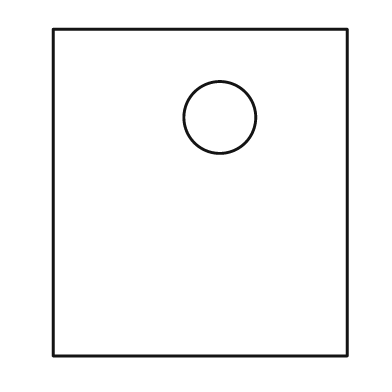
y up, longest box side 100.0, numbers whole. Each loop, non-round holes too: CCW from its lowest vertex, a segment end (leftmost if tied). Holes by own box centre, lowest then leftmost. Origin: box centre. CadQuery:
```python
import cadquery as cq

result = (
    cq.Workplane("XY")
    .moveTo(-45.0, -50.0)
    .lineTo(45.0, -50.0)
    .lineTo(45.0, 50.0)
    .lineTo(-45.0, 50.0)
    .close()
    .moveTo(6.0, 23.0)
    .circle(11.0)
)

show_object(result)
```